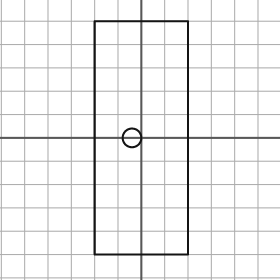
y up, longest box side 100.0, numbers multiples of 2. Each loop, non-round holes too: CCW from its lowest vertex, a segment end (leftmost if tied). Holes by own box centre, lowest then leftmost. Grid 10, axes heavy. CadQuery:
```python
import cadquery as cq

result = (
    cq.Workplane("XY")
    .moveTo(-20.0, -50.0)
    .lineTo(20.0, -50.0)
    .lineTo(20.0, 50.0)
    .lineTo(-20.0, 50.0)
    .close()
    .moveTo(-4.0, 0.0)
    .circle(4.0)
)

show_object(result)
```